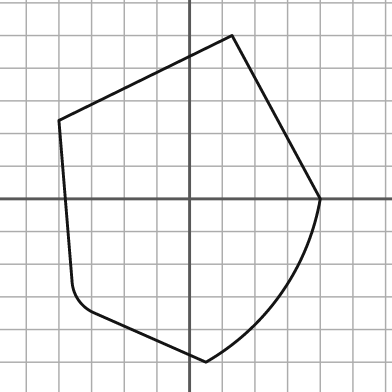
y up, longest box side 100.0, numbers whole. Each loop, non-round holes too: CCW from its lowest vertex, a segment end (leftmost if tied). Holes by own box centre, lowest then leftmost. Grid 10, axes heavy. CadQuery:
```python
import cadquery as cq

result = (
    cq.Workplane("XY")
    .moveTo(5.0, -50.0)
    .threePointArc((28.0, -29.0), (40.0, 0.0))
    .lineTo(13.0, 50.0)
    .lineTo(-40.0, 24.0)
    .lineTo(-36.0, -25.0)
    .threePointArc((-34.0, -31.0), (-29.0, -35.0))
    .close()
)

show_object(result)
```